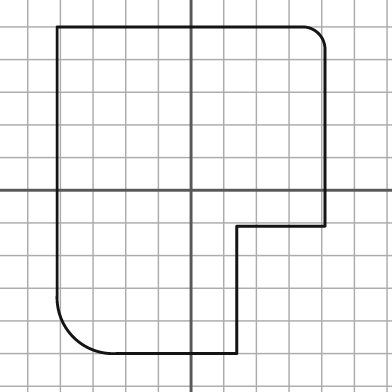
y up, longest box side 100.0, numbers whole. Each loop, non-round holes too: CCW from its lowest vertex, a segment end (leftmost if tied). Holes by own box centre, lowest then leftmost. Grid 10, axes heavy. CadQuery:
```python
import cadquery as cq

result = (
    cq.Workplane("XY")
    .moveTo(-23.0, -50.0)
    .lineTo(14.0, -50.0)
    .lineTo(14.0, -11.0)
    .lineTo(41.0, -11.0)
    .lineTo(41.0, 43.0)
    .threePointArc((39.0, 48.0), (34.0, 50.0))
    .lineTo(-41.0, 50.0)
    .lineTo(-41.0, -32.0)
    .threePointArc((-36.0, -45.0), (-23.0, -50.0))
    .close()
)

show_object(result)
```